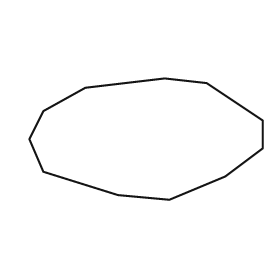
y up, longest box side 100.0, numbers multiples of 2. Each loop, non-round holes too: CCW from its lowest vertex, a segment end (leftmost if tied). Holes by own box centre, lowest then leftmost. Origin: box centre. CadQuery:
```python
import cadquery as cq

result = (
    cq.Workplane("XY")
    .moveTo(10.0, -26.0)
    .lineTo(34.0, -16.0)
    .lineTo(50.0, -4.0)
    .lineTo(50.0, 8.0)
    .lineTo(26.0, 24.0)
    .lineTo(8.0, 26.0)
    .lineTo(-26.0, 22.0)
    .lineTo(-44.0, 12.0)
    .lineTo(-50.0, 0.0)
    .lineTo(-44.0, -14.0)
    .lineTo(-12.0, -24.0)
    .close()
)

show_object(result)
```